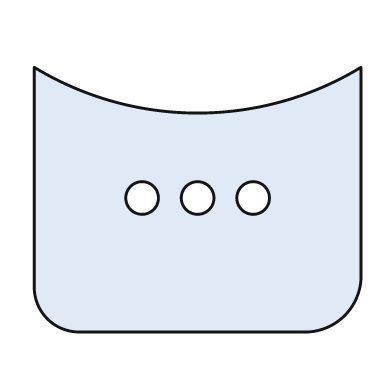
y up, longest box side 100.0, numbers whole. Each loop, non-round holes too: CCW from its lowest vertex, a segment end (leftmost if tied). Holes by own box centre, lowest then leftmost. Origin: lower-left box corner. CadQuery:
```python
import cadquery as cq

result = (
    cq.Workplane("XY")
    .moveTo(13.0, 0.0)
    .lineTo(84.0, 0.0)
    .threePointArc((95.0, 5.0), (100.0, 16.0))
    .lineTo(100.0, 81.0)
    .threePointArc((50.0, 67.0), (0.0, 81.0))
    .lineTo(0.0, 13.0)
    .threePointArc((4.0, 4.0), (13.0, 0.0))
    .close()
    .moveTo(33.0, 41.0)
    .circle(5.0)
    .moveTo(50.0, 41.0)
    .circle(5.0)
    .moveTo(67.0, 41.0)
    .circle(5.0)
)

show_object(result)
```